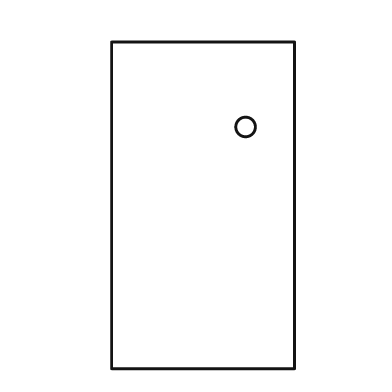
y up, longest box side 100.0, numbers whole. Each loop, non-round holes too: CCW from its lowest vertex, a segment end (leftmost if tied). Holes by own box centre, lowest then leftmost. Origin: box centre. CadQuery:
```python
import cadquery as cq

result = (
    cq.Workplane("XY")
    .moveTo(-28.0, -50.0)
    .lineTo(28.0, -50.0)
    .lineTo(28.0, 50.0)
    .lineTo(-28.0, 50.0)
    .close()
    .moveTo(13.0, 24.0)
    .circle(3.0)
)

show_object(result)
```